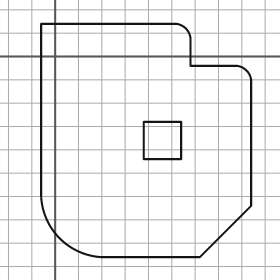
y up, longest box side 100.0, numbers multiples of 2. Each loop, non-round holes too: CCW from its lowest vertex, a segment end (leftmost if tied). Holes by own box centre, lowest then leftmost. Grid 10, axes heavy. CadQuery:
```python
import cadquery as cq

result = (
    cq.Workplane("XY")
    .moveTo(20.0, -86.0)
    .lineTo(62.0, -86.0)
    .lineTo(84.0, -64.0)
    .lineTo(84.0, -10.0)
    .threePointArc((82.0, -6.0), (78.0, -4.0))
    .lineTo(58.0, -4.0)
    .lineTo(58.0, 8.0)
    .threePointArc((56.0, 12.0), (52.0, 14.0))
    .lineTo(-6.0, 14.0)
    .lineTo(-6.0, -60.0)
    .threePointArc((2.0, -78.0), (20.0, -86.0))
    .close()
    .moveTo(38.0, -44.0)
    .lineTo(54.0, -44.0)
    .lineTo(54.0, -28.0)
    .lineTo(38.0, -28.0)
    .close()
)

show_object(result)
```